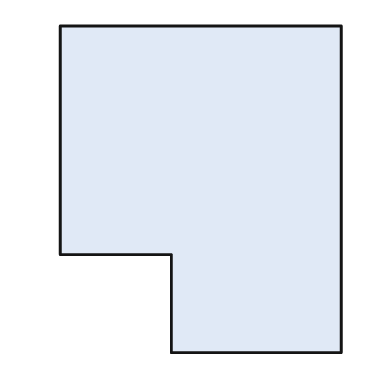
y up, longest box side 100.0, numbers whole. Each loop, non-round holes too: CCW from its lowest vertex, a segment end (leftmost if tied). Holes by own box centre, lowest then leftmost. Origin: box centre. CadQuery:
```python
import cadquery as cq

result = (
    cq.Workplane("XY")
    .moveTo(-9.0, -50.0)
    .lineTo(43.0, -50.0)
    .lineTo(43.0, 50.0)
    .lineTo(-43.0, 50.0)
    .lineTo(-43.0, -20.0)
    .lineTo(-9.0, -20.0)
    .close()
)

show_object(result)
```